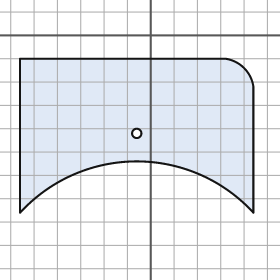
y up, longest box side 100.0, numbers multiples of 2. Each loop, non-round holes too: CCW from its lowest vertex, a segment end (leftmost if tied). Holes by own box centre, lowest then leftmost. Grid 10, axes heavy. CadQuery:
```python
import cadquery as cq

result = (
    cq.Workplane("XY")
    .moveTo(-56.0, -76.0)
    .threePointArc((-6.0, -54.0), (44.0, -76.0))
    .lineTo(44.0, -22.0)
    .threePointArc((40.0, -14.0), (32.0, -10.0))
    .lineTo(-56.0, -10.0)
    .close()
    .moveTo(-6.0, -42.0)
    .circle(2.0)
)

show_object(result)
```